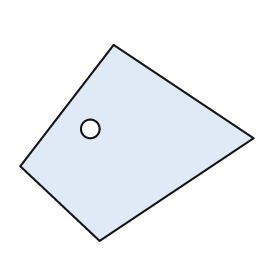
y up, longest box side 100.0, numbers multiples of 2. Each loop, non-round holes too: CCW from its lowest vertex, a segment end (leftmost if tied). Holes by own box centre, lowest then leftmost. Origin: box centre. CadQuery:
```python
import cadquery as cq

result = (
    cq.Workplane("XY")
    .moveTo(-16.0, -42.0)
    .lineTo(50.0, 2.0)
    .lineTo(-10.0, 42.0)
    .lineTo(-50.0, -10.0)
    .close()
    .moveTo(-20.0, 6.0)
    .circle(4.0)
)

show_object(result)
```